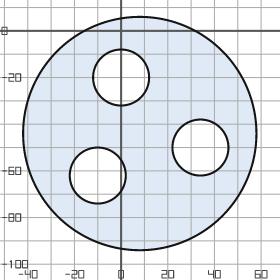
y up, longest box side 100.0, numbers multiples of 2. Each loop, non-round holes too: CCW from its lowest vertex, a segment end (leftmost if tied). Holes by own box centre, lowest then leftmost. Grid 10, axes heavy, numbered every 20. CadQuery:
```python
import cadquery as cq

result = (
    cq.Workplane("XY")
    .moveTo(8.0, -44.0)
    .circle(50.0)
    .moveTo(-10.0, -62.0)
    .circle(12.0)
    .moveTo(34.0, -50.0)
    .circle(12.0)
    .moveTo(0.0, -20.0)
    .circle(12.0)
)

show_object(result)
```